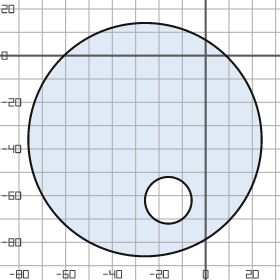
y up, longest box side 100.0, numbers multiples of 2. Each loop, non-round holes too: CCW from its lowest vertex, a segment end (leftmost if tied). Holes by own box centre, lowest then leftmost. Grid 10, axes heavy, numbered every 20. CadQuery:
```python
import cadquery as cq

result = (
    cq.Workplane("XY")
    .moveTo(-26.0, -36.0)
    .circle(50.0)
    .moveTo(-16.0, -62.0)
    .circle(10.0)
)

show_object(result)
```